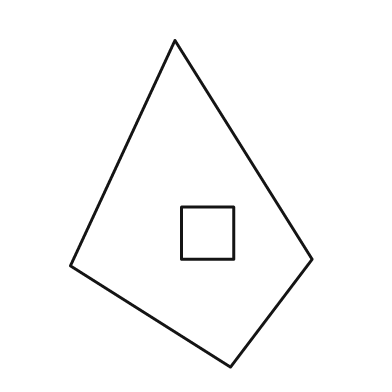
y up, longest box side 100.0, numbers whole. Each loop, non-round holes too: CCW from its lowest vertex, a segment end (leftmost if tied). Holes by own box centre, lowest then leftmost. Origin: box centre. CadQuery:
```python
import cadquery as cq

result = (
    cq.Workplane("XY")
    .moveTo(12.0, -50.0)
    .lineTo(37.0, -17.0)
    .lineTo(-5.0, 50.0)
    .lineTo(-37.0, -19.0)
    .close()
    .moveTo(-3.0, -17.0)
    .lineTo(13.0, -17.0)
    .lineTo(13.0, -1.0)
    .lineTo(-3.0, -1.0)
    .close()
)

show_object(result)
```